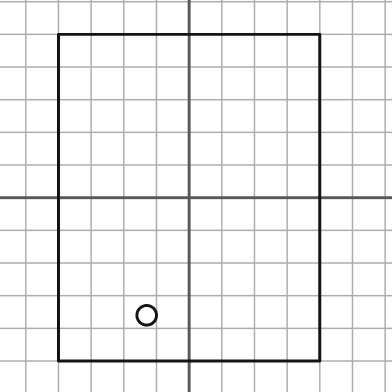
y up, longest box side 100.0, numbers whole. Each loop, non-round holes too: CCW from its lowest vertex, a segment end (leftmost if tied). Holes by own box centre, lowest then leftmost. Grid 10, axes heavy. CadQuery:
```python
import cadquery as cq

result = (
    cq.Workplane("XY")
    .moveTo(-40.0, -50.0)
    .lineTo(40.0, -50.0)
    .lineTo(40.0, 50.0)
    .lineTo(-40.0, 50.0)
    .close()
    .moveTo(-13.0, -36.0)
    .circle(3.0)
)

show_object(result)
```